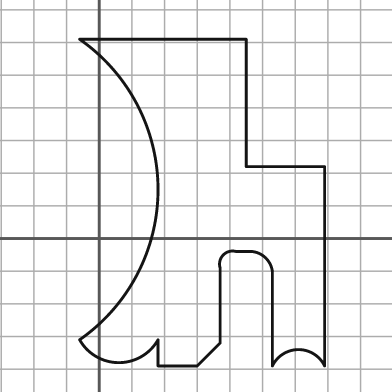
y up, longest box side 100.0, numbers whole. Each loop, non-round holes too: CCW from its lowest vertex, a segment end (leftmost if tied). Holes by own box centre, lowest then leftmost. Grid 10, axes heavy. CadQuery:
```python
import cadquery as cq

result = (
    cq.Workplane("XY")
    .moveTo(18.0, -39.0)
    .lineTo(30.0, -39.0)
    .lineTo(37.0, -32.0)
    .lineTo(37.0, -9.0)
    .threePointArc((38.0, -5.0), (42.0, -4.0))
    .lineTo(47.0, -4.0)
    .threePointArc((51.0, -6.0), (53.0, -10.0))
    .lineTo(53.0, -39.0)
    .threePointArc((61.0, -34.0), (69.0, -39.0))
    .lineTo(69.0, 22.0)
    .lineTo(45.0, 22.0)
    .lineTo(45.0, 61.0)
    .lineTo(-6.0, 61.0)
    .threePointArc((18.0, 15.0), (-6.0, -31.0))
    .threePointArc((6.0, -38.0), (18.0, -31.0))
    .close()
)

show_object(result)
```